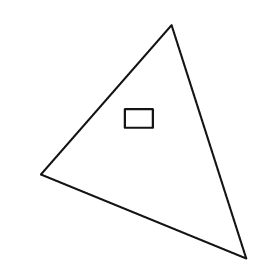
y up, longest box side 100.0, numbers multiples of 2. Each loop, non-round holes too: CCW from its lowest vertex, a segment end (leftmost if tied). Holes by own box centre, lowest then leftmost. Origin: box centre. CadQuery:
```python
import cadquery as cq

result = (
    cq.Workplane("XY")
    .moveTo(44.0, -50.0)
    .lineTo(12.0, 50.0)
    .lineTo(-44.0, -14.0)
    .close()
    .moveTo(-8.0, 6.0)
    .lineTo(4.0, 6.0)
    .lineTo(4.0, 14.0)
    .lineTo(-8.0, 14.0)
    .close()
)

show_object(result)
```